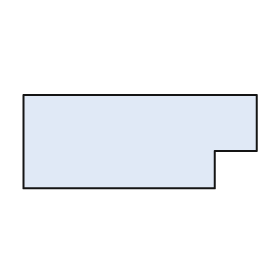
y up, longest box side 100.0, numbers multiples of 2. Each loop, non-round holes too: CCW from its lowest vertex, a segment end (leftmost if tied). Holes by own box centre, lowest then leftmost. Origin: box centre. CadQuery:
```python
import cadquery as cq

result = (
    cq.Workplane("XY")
    .moveTo(-50.0, -20.0)
    .lineTo(32.0, -20.0)
    .lineTo(32.0, -4.0)
    .lineTo(50.0, -4.0)
    .lineTo(50.0, 20.0)
    .lineTo(-50.0, 20.0)
    .close()
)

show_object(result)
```